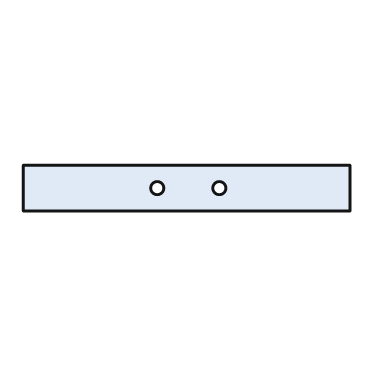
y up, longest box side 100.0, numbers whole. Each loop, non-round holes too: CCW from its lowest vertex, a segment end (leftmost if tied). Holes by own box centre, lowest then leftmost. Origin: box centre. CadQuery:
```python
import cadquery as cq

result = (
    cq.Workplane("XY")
    .moveTo(-50.0, -7.0)
    .lineTo(50.0, -7.0)
    .lineTo(50.0, 7.0)
    .lineTo(-50.0, 7.0)
    .close()
    .moveTo(-9.0, 0.0)
    .circle(2.0)
    .moveTo(10.0, 0.0)
    .circle(2.0)
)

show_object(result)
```